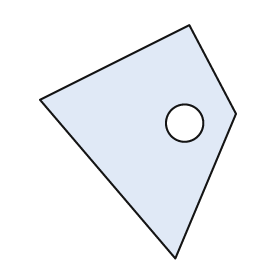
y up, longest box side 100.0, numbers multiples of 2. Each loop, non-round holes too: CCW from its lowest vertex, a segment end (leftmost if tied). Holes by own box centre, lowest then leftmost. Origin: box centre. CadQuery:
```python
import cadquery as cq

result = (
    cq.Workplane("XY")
    .moveTo(16.0, -50.0)
    .lineTo(42.0, 12.0)
    .lineTo(22.0, 50.0)
    .lineTo(-42.0, 18.0)
    .close()
    .moveTo(20.0, 8.0)
    .circle(8.0)
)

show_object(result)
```